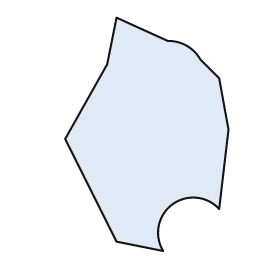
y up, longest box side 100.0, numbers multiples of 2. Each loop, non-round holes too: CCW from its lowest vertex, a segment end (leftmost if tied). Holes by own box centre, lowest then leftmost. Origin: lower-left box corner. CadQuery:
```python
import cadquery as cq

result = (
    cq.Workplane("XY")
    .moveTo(42.0, 0.0)
    .threePointArc((46.0, 20.0), (66.0, 18.0))
    .lineTo(70.0, 52.0)
    .lineTo(66.0, 74.0)
    .lineTo(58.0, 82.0)
    .threePointArc((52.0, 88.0), (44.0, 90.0))
    .lineTo(22.0, 100.0)
    .lineTo(18.0, 80.0)
    .lineTo(0.0, 48.0)
    .lineTo(22.0, 4.0)
    .close()
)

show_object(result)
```